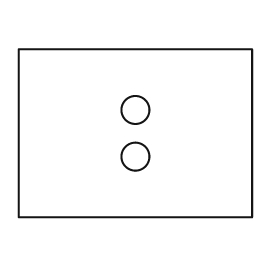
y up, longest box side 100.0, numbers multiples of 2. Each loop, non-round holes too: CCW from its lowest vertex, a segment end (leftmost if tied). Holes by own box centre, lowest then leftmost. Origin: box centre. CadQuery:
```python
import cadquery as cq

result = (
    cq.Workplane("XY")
    .moveTo(-50.0, -36.0)
    .lineTo(50.0, -36.0)
    .lineTo(50.0, 36.0)
    .lineTo(-50.0, 36.0)
    .close()
    .moveTo(0.0, -10.0)
    .circle(6.0)
    .moveTo(0.0, 10.0)
    .circle(6.0)
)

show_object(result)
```